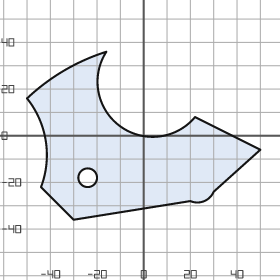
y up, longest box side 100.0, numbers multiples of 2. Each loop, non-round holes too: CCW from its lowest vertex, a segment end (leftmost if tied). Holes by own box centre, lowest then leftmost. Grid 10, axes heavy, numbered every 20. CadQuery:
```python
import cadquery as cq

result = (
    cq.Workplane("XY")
    .moveTo(-30.0, -36.0)
    .lineTo(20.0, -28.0)
    .threePointArc((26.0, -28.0), (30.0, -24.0))
    .lineTo(50.0, -6.0)
    .lineTo(22.0, 8.0)
    .threePointArc((-10.0, 4.0), (-16.0, 36.0))
    .threePointArc((-34.0, 28.0), (-50.0, 16.0))
    .threePointArc((-42.0, -2.0), (-44.0, -22.0))
    .close()
    .moveTo(-24.0, -18.0)
    .circle(4.0)
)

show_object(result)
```